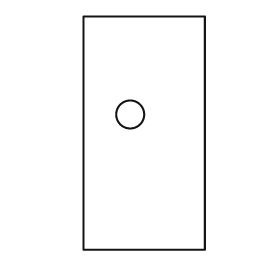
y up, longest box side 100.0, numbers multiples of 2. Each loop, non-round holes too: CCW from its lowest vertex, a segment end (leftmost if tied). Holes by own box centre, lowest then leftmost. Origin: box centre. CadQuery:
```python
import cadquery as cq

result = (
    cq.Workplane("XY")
    .moveTo(-26.0, -50.0)
    .lineTo(26.0, -50.0)
    .lineTo(26.0, 50.0)
    .lineTo(-26.0, 50.0)
    .close()
    .moveTo(-6.0, 8.0)
    .circle(6.0)
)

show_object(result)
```